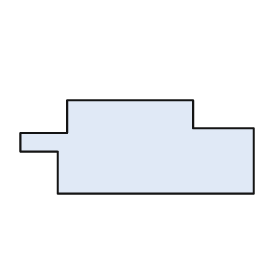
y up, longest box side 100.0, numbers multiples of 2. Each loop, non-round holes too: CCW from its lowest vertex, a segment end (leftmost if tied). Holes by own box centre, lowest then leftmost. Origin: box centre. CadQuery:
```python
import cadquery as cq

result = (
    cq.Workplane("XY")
    .moveTo(-34.0, -20.0)
    .lineTo(50.0, -20.0)
    .lineTo(50.0, 8.0)
    .lineTo(24.0, 8.0)
    .lineTo(24.0, 20.0)
    .lineTo(-30.0, 20.0)
    .lineTo(-30.0, 6.0)
    .lineTo(-50.0, 6.0)
    .lineTo(-50.0, -2.0)
    .lineTo(-34.0, -2.0)
    .close()
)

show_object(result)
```